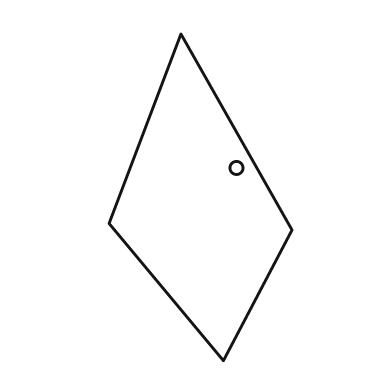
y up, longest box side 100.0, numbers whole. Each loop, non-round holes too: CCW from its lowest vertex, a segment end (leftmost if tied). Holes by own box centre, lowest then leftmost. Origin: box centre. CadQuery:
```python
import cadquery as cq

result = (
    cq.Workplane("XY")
    .moveTo(7.0, -50.0)
    .lineTo(28.0, -10.0)
    .lineTo(-6.0, 50.0)
    .lineTo(-28.0, -8.0)
    .close()
    .moveTo(11.0, 9.0)
    .circle(2.0)
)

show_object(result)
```